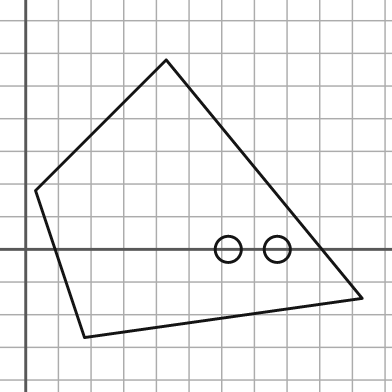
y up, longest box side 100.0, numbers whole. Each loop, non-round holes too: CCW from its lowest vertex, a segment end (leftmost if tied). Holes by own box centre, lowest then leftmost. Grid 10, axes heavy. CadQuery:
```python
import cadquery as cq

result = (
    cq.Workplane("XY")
    .moveTo(18.0, -27.0)
    .lineTo(103.0, -15.0)
    .lineTo(43.0, 58.0)
    .lineTo(3.0, 18.0)
    .close()
    .moveTo(62.0, 0.0)
    .circle(4.0)
    .moveTo(77.0, 0.0)
    .circle(4.0)
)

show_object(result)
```